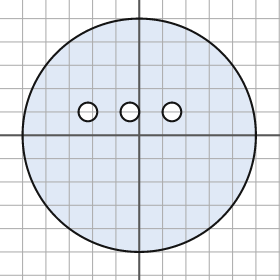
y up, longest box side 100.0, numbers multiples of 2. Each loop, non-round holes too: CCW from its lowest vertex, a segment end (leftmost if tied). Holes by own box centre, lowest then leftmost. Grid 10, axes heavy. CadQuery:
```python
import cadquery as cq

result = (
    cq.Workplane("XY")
    .moveTo(0.0, 0.0)
    .circle(50.0)
    .moveTo(-22.0, 10.0)
    .circle(4.0)
    .moveTo(-4.0, 10.0)
    .circle(4.0)
    .moveTo(14.0, 10.0)
    .circle(4.0)
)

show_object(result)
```